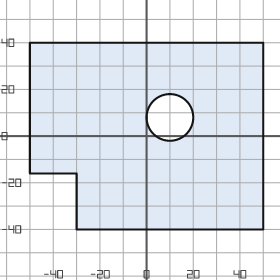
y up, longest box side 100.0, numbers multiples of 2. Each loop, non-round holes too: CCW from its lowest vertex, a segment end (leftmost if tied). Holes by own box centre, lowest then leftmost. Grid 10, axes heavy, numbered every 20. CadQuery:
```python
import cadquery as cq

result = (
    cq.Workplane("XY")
    .moveTo(-30.0, -40.0)
    .lineTo(50.0, -40.0)
    .lineTo(50.0, 40.0)
    .lineTo(-50.0, 40.0)
    .lineTo(-50.0, -16.0)
    .lineTo(-30.0, -16.0)
    .close()
    .moveTo(10.0, 8.0)
    .circle(10.0)
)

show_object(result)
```